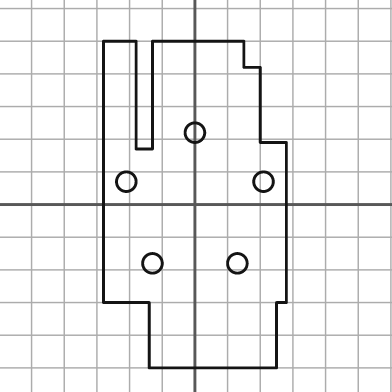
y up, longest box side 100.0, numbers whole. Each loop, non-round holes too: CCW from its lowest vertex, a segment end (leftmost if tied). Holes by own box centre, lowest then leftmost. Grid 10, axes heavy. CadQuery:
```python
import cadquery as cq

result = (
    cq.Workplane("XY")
    .moveTo(-14.0, -50.0)
    .lineTo(25.0, -50.0)
    .lineTo(25.0, -30.0)
    .lineTo(28.0, -30.0)
    .lineTo(28.0, 19.0)
    .lineTo(20.0, 19.0)
    .lineTo(20.0, 42.0)
    .lineTo(15.0, 42.0)
    .lineTo(15.0, 50.0)
    .lineTo(-13.0, 50.0)
    .lineTo(-13.0, 17.0)
    .lineTo(-18.0, 17.0)
    .lineTo(-18.0, 50.0)
    .lineTo(-28.0, 50.0)
    .lineTo(-28.0, -30.0)
    .lineTo(-14.0, -30.0)
    .close()
    .moveTo(-13.0, -18.0)
    .circle(3.0)
    .moveTo(13.0, -18.0)
    .circle(3.0)
    .moveTo(-21.0, 7.0)
    .circle(3.0)
    .moveTo(21.0, 7.0)
    .circle(3.0)
    .moveTo(0.0, 22.0)
    .circle(3.0)
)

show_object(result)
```